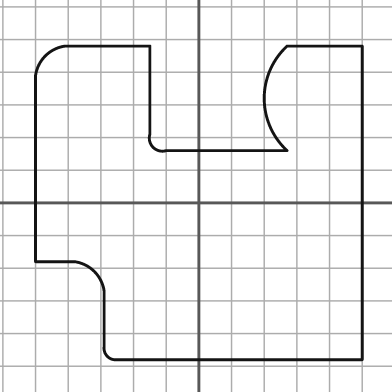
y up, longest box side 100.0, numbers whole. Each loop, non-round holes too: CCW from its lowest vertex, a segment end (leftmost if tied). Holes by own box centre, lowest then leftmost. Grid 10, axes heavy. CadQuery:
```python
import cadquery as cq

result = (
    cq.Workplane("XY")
    .moveTo(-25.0, -48.0)
    .lineTo(50.0, -48.0)
    .lineTo(50.0, 48.0)
    .lineTo(27.0, 48.0)
    .threePointArc((20.0, 32.0), (27.0, 16.0))
    .lineTo(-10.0, 16.0)
    .threePointArc((-14.0, 17.0), (-15.0, 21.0))
    .lineTo(-15.0, 48.0)
    .lineTo(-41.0, 48.0)
    .threePointArc((-47.0, 45.0), (-50.0, 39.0))
    .lineTo(-50.0, -18.0)
    .lineTo(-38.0, -18.0)
    .threePointArc((-32.0, -21.0), (-29.0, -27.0))
    .lineTo(-29.0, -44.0)
    .threePointArc((-28.0, -47.0), (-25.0, -48.0))
    .close()
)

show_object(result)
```